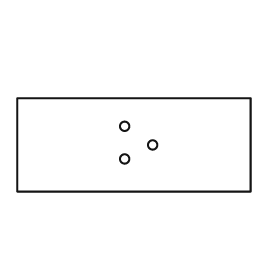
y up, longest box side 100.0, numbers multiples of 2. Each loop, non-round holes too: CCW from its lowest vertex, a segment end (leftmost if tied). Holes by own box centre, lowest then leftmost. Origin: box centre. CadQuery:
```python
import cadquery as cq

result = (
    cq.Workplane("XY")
    .moveTo(-50.0, -20.0)
    .lineTo(50.0, -20.0)
    .lineTo(50.0, 20.0)
    .lineTo(-50.0, 20.0)
    .close()
    .moveTo(-4.0, -6.0)
    .circle(2.0)
    .moveTo(8.0, 0.0)
    .circle(2.0)
    .moveTo(-4.0, 8.0)
    .circle(2.0)
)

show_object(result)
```